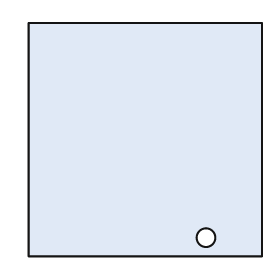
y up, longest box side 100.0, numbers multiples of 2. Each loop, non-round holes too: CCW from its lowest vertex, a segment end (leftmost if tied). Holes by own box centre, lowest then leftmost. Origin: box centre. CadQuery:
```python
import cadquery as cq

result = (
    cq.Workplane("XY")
    .moveTo(-50.0, -50.0)
    .lineTo(50.0, -50.0)
    .lineTo(50.0, 50.0)
    .lineTo(-50.0, 50.0)
    .close()
    .moveTo(26.0, -42.0)
    .circle(4.0)
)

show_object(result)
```